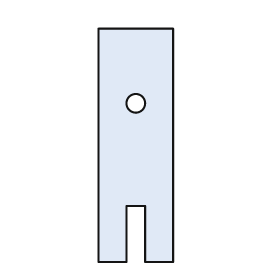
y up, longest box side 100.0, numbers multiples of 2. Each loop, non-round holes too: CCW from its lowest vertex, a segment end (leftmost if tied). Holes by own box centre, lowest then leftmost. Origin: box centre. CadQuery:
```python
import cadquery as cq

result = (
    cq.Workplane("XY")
    .moveTo(-16.0, -50.0)
    .lineTo(-4.0, -50.0)
    .lineTo(-4.0, -26.0)
    .lineTo(4.0, -26.0)
    .lineTo(4.0, -50.0)
    .lineTo(16.0, -50.0)
    .lineTo(16.0, 50.0)
    .lineTo(-16.0, 50.0)
    .close()
    .moveTo(0.0, 18.0)
    .circle(4.0)
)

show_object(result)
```